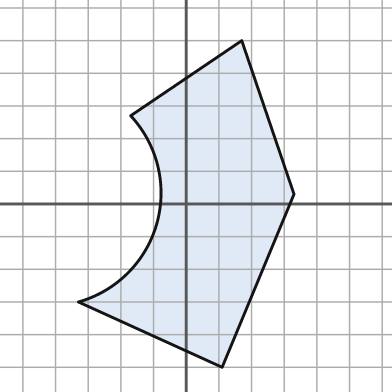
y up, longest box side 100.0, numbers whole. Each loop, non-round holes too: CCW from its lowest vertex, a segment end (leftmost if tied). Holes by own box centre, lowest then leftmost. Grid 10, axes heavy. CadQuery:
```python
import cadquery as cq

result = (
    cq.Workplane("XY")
    .moveTo(11.0, -50.0)
    .lineTo(33.0, 3.0)
    .lineTo(17.0, 50.0)
    .lineTo(-17.0, 27.0)
    .threePointArc((-9.0, -6.0), (-33.0, -30.0))
    .close()
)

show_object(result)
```